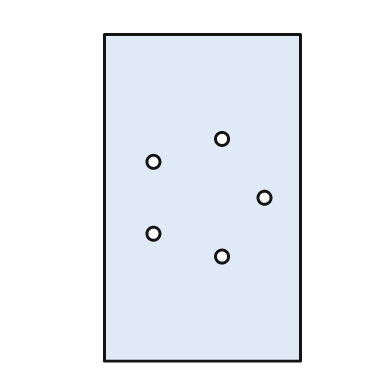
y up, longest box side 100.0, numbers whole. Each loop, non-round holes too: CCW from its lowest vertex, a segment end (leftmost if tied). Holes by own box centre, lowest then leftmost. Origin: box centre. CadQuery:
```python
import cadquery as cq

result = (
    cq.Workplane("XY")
    .moveTo(-30.0, -50.0)
    .lineTo(30.0, -50.0)
    .lineTo(30.0, 50.0)
    .lineTo(-30.0, 50.0)
    .close()
    .moveTo(6.0, -18.0)
    .circle(2.0)
    .moveTo(-15.0, -11.0)
    .circle(2.0)
    .moveTo(19.0, 0.0)
    .circle(2.0)
    .moveTo(-15.0, 11.0)
    .circle(2.0)
    .moveTo(6.0, 18.0)
    .circle(2.0)
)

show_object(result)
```